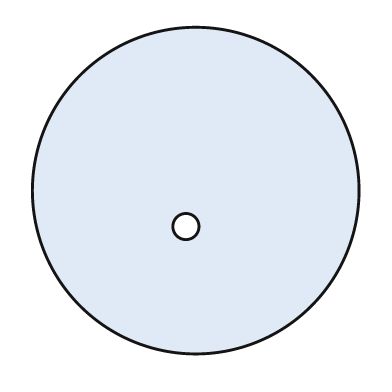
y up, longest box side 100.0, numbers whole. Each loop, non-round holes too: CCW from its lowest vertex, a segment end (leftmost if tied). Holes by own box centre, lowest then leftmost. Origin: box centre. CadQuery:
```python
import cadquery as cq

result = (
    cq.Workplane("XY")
    .moveTo(0.0, 0.0)
    .circle(50.0)
    .moveTo(-3.0, -11.0)
    .circle(4.0)
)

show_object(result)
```